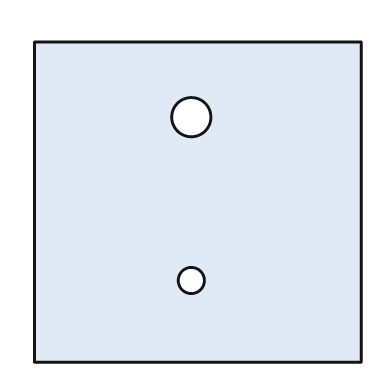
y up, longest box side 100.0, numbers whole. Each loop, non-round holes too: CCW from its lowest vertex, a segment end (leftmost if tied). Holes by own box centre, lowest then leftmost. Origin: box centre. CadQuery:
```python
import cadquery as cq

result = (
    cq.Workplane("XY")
    .moveTo(-50.0, -49.0)
    .lineTo(50.0, -49.0)
    .lineTo(50.0, 49.0)
    .lineTo(-50.0, 49.0)
    .close()
    .moveTo(-2.0, -24.0)
    .circle(4.0)
    .moveTo(-2.0, 26.0)
    .circle(6.0)
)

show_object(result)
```